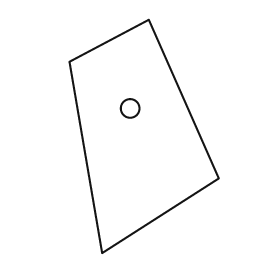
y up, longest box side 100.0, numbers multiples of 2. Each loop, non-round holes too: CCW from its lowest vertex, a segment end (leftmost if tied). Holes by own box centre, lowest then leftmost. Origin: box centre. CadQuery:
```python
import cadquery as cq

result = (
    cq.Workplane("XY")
    .moveTo(-18.0, -50.0)
    .lineTo(32.0, -18.0)
    .lineTo(2.0, 50.0)
    .lineTo(-32.0, 32.0)
    .close()
    .moveTo(-6.0, 12.0)
    .circle(4.0)
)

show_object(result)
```